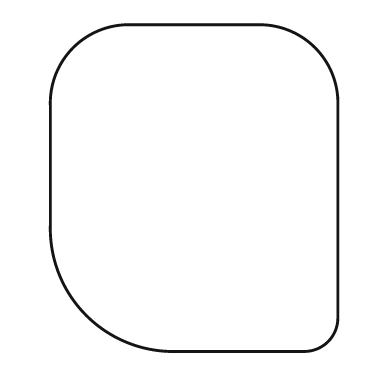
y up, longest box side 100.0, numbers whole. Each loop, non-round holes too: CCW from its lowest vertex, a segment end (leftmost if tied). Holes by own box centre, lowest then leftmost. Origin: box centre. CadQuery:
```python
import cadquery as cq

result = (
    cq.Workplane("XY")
    .moveTo(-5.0, -50.0)
    .lineTo(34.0, -50.0)
    .threePointArc((41.0, -47.0), (44.0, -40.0))
    .lineTo(44.0, 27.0)
    .threePointArc((37.0, 43.0), (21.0, 50.0))
    .lineTo(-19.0, 50.0)
    .threePointArc((-37.0, 43.0), (-44.0, 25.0))
    .lineTo(-44.0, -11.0)
    .threePointArc((-33.0, -39.0), (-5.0, -50.0))
    .close()
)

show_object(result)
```